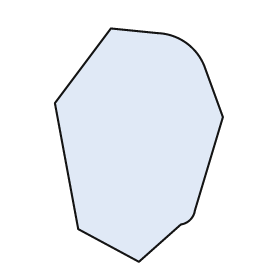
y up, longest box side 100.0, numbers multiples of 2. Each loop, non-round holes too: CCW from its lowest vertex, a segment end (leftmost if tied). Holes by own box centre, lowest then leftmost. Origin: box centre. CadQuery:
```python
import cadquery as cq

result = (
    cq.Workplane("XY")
    .moveTo(0.0, -50.0)
    .lineTo(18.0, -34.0)
    .threePointArc((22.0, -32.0), (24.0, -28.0))
    .lineTo(36.0, 12.0)
    .lineTo(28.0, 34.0)
    .threePointArc((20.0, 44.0), (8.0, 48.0))
    .lineTo(-12.0, 50.0)
    .lineTo(-36.0, 18.0)
    .lineTo(-26.0, -36.0)
    .close()
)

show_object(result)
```